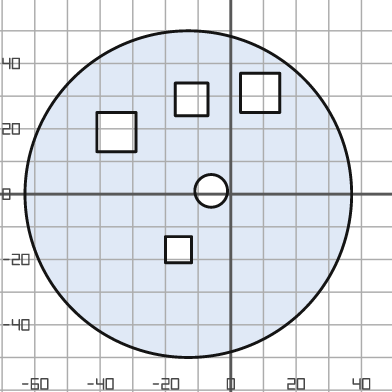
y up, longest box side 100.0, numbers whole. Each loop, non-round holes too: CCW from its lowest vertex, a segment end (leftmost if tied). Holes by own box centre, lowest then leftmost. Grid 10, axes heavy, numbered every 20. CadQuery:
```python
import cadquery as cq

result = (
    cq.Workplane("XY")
    .moveTo(-13.0, 0.0)
    .circle(50.0)
    .moveTo(-20.0, -21.0)
    .lineTo(-12.0, -21.0)
    .lineTo(-12.0, -13.0)
    .lineTo(-20.0, -13.0)
    .close()
    .moveTo(-6.0, 1.0)
    .circle(5.0)
    .moveTo(-41.0, 13.0)
    .lineTo(-29.0, 13.0)
    .lineTo(-29.0, 25.0)
    .lineTo(-41.0, 25.0)
    .close()
    .moveTo(-17.0, 24.0)
    .lineTo(-7.0, 24.0)
    .lineTo(-7.0, 34.0)
    .lineTo(-17.0, 34.0)
    .close()
    .moveTo(3.0, 25.0)
    .lineTo(15.0, 25.0)
    .lineTo(15.0, 37.0)
    .lineTo(3.0, 37.0)
    .close()
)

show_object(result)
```